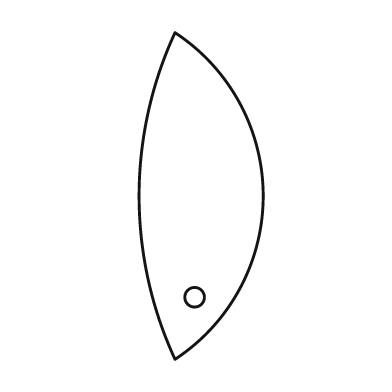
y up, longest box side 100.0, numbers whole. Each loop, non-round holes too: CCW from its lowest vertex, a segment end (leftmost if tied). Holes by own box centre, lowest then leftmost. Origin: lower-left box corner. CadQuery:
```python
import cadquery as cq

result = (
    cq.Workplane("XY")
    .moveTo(11.0, 0.0)
    .threePointArc((38.0, 50.0), (11.0, 100.0))
    .threePointArc((0.0, 50.0), (11.0, 0.0))
    .close()
    .moveTo(17.0, 19.0)
    .circle(3.0)
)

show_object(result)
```